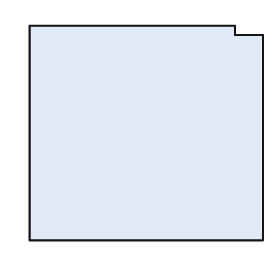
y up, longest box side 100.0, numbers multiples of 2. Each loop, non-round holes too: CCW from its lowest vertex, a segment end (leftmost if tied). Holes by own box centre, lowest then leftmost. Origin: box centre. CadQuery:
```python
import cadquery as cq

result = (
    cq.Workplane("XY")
    .moveTo(-50.0, -46.0)
    .lineTo(50.0, -46.0)
    .lineTo(50.0, 42.0)
    .lineTo(38.0, 42.0)
    .lineTo(38.0, 46.0)
    .lineTo(-50.0, 46.0)
    .close()
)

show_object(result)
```